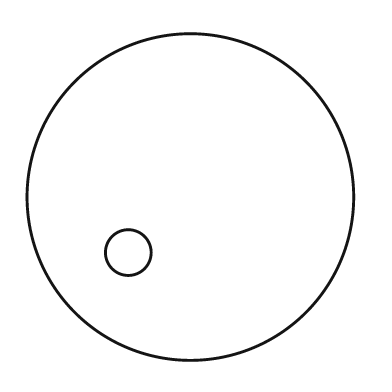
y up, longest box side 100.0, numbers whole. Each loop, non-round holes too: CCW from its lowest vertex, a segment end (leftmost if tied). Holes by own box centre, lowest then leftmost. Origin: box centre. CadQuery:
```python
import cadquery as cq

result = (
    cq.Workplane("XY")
    .moveTo(0.0, 0.0)
    .circle(50.0)
    .moveTo(-19.0, -17.0)
    .circle(7.0)
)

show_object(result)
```